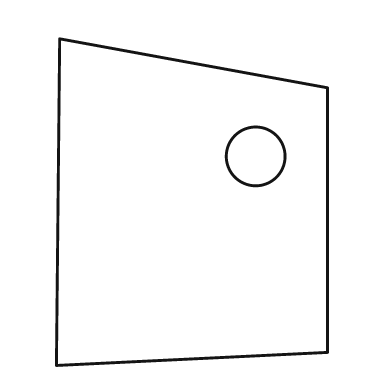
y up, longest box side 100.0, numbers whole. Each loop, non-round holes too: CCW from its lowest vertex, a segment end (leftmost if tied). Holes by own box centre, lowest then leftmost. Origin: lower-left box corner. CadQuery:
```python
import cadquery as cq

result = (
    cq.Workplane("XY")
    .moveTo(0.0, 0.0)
    .lineTo(83.0, 4.0)
    .lineTo(83.0, 85.0)
    .lineTo(1.0, 100.0)
    .close()
    .moveTo(61.0, 64.0)
    .circle(9.0)
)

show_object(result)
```